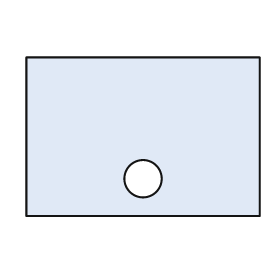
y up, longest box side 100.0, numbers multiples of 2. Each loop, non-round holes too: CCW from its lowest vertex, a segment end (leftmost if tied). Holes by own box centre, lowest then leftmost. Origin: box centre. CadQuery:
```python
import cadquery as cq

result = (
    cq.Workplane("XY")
    .moveTo(-50.0, -34.0)
    .lineTo(50.0, -34.0)
    .lineTo(50.0, 34.0)
    .lineTo(-50.0, 34.0)
    .close()
    .moveTo(0.0, -18.0)
    .circle(8.0)
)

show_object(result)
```